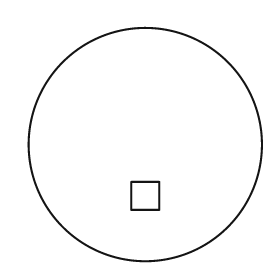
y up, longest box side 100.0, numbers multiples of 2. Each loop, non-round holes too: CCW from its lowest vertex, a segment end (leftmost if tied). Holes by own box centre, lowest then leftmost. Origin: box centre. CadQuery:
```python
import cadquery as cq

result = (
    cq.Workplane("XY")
    .moveTo(0.0, 0.0)
    .circle(50.0)
    .moveTo(-6.0, -28.0)
    .lineTo(6.0, -28.0)
    .lineTo(6.0, -16.0)
    .lineTo(-6.0, -16.0)
    .close()
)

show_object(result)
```